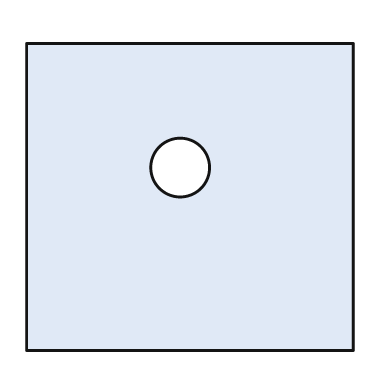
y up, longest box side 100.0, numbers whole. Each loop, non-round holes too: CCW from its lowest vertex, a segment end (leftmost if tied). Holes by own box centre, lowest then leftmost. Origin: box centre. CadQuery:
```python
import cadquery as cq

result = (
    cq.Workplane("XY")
    .moveTo(-50.0, -47.0)
    .lineTo(50.0, -47.0)
    .lineTo(50.0, 47.0)
    .lineTo(-50.0, 47.0)
    .close()
    .moveTo(-3.0, 9.0)
    .circle(9.0)
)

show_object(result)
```